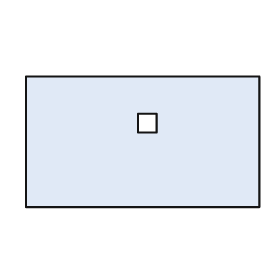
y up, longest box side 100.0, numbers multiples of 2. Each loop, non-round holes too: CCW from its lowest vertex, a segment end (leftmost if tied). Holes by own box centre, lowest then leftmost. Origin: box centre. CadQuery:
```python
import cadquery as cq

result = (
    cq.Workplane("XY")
    .moveTo(-50.0, -28.0)
    .lineTo(50.0, -28.0)
    .lineTo(50.0, 28.0)
    .lineTo(-50.0, 28.0)
    .close()
    .moveTo(-2.0, 4.0)
    .lineTo(6.0, 4.0)
    .lineTo(6.0, 12.0)
    .lineTo(-2.0, 12.0)
    .close()
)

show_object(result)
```